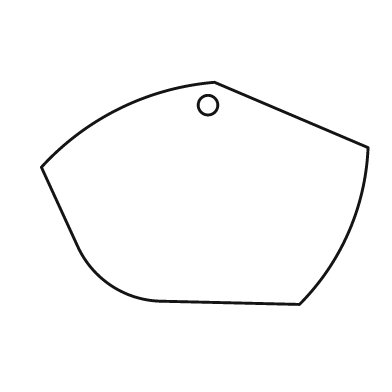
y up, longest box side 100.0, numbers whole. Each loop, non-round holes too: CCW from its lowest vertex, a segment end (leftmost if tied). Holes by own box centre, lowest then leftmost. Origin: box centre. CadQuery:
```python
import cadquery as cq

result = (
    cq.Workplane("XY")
    .moveTo(29.0, -34.0)
    .threePointArc((44.0, -12.0), (50.0, 14.0))
    .lineTo(3.0, 34.0)
    .threePointArc((-26.0, 26.0), (-50.0, 8.0))
    .lineTo(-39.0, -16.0)
    .threePointArc((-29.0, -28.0), (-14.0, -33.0))
    .close()
    .moveTo(1.0, 27.0)
    .circle(3.0)
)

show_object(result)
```